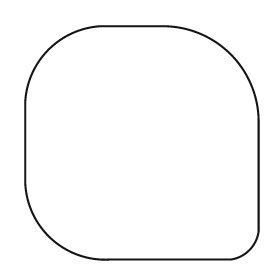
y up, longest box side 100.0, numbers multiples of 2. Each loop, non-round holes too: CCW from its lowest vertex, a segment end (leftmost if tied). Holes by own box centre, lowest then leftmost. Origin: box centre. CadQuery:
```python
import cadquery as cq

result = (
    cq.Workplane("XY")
    .moveTo(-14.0, -50.0)
    .lineTo(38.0, -50.0)
    .threePointArc((46.0, -46.0), (50.0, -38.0))
    .lineTo(50.0, 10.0)
    .threePointArc((38.0, 38.0), (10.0, 50.0))
    .lineTo(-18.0, 50.0)
    .threePointArc((-40.0, 40.0), (-50.0, 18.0))
    .lineTo(-50.0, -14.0)
    .threePointArc((-40.0, -40.0), (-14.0, -50.0))
    .close()
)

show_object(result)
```